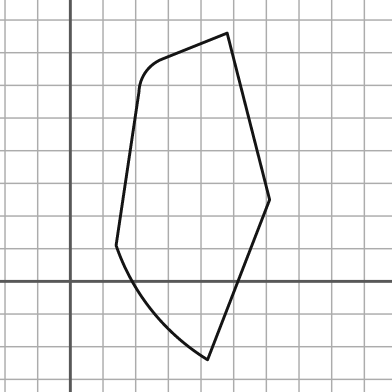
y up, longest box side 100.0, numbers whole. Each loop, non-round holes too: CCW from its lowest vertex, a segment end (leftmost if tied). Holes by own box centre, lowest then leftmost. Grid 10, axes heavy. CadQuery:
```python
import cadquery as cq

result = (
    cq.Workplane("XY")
    .moveTo(42.0, -24.0)
    .lineTo(61.0, 25.0)
    .lineTo(48.0, 76.0)
    .lineTo(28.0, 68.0)
    .threePointArc((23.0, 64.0), (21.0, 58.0))
    .lineTo(14.0, 11.0)
    .threePointArc((25.0, -9.0), (42.0, -24.0))
    .close()
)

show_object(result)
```